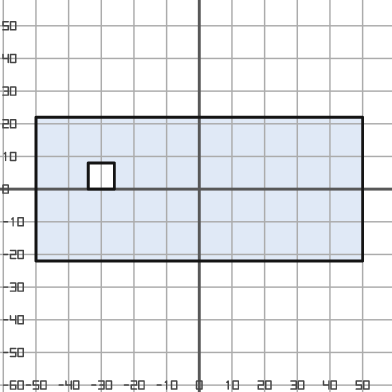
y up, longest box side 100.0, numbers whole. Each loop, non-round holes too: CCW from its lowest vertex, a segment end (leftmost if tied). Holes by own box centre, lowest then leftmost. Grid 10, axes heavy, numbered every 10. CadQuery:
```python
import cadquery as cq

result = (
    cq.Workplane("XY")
    .moveTo(-50.0, -22.0)
    .lineTo(50.0, -22.0)
    .lineTo(50.0, 22.0)
    .lineTo(-50.0, 22.0)
    .close()
    .moveTo(-34.0, 0.0)
    .lineTo(-26.0, 0.0)
    .lineTo(-26.0, 8.0)
    .lineTo(-34.0, 8.0)
    .close()
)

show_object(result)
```